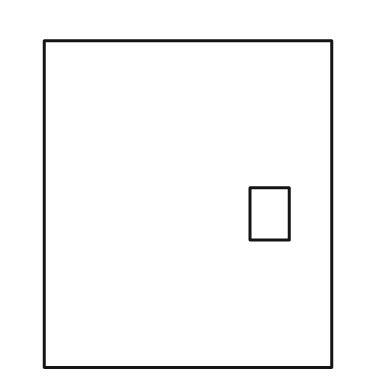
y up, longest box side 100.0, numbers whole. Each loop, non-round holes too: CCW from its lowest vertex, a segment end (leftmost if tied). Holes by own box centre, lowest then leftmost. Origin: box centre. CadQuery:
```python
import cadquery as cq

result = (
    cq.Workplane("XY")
    .moveTo(-44.0, -50.0)
    .lineTo(44.0, -50.0)
    .lineTo(44.0, 50.0)
    .lineTo(-44.0, 50.0)
    .close()
    .moveTo(19.0, -11.0)
    .lineTo(31.0, -11.0)
    .lineTo(31.0, 5.0)
    .lineTo(19.0, 5.0)
    .close()
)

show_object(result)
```